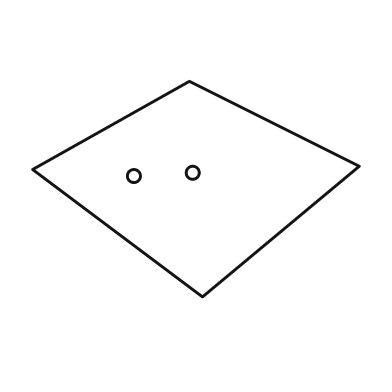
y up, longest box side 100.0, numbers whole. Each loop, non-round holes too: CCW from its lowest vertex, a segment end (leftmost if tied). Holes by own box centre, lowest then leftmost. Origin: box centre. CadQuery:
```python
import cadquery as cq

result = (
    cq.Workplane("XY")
    .moveTo(2.0, -33.0)
    .lineTo(50.0, 7.0)
    .lineTo(-2.0, 33.0)
    .lineTo(-50.0, 6.0)
    .close()
    .moveTo(-19.0, 4.0)
    .circle(2.0)
    .moveTo(-1.0, 5.0)
    .circle(2.0)
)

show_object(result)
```